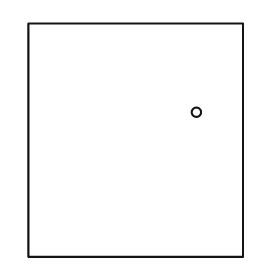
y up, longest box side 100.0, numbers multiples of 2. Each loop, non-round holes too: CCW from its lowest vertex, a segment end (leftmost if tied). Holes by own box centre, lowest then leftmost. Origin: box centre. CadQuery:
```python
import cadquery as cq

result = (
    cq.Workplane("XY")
    .moveTo(-46.0, -50.0)
    .lineTo(46.0, -50.0)
    .lineTo(46.0, 50.0)
    .lineTo(-46.0, 50.0)
    .close()
    .moveTo(26.0, 12.0)
    .circle(2.0)
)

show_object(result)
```